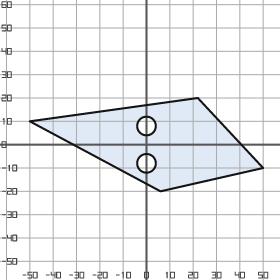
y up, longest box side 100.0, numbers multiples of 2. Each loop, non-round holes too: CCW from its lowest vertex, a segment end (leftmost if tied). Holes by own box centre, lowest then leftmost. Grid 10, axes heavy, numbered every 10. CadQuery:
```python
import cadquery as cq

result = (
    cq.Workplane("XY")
    .moveTo(6.0, -20.0)
    .lineTo(50.0, -10.0)
    .lineTo(22.0, 20.0)
    .lineTo(-50.0, 10.0)
    .close()
    .moveTo(0.0, -8.0)
    .circle(4.0)
    .moveTo(0.0, 8.0)
    .circle(4.0)
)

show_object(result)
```